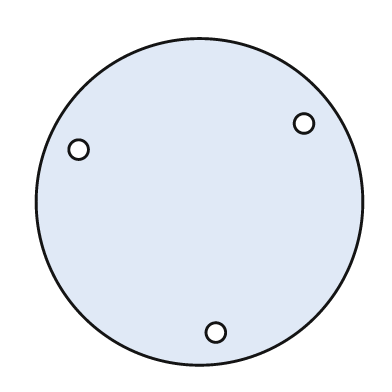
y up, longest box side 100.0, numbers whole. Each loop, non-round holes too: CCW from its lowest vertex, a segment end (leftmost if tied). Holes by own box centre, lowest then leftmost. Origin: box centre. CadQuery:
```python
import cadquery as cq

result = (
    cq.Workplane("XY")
    .moveTo(0.0, 0.0)
    .circle(50.0)
    .moveTo(5.0, -40.0)
    .circle(3.0)
    .moveTo(-37.0, 16.0)
    .circle(3.0)
    .moveTo(32.0, 24.0)
    .circle(3.0)
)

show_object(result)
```